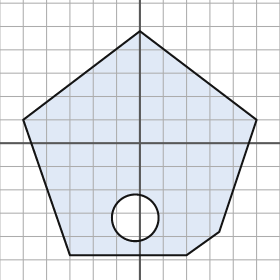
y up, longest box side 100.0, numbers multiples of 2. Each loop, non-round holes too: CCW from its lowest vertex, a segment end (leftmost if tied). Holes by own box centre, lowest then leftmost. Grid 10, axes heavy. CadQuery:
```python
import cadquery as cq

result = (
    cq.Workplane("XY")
    .moveTo(-30.0, -48.0)
    .lineTo(20.0, -48.0)
    .lineTo(34.0, -38.0)
    .lineTo(50.0, 10.0)
    .lineTo(0.0, 48.0)
    .lineTo(-50.0, 10.0)
    .close()
    .moveTo(-2.0, -32.0)
    .circle(10.0)
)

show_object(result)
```